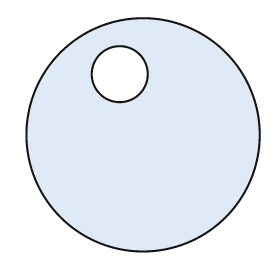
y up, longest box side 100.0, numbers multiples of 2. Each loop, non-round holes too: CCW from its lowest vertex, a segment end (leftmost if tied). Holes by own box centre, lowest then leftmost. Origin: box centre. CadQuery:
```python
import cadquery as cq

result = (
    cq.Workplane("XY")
    .moveTo(0.0, 0.0)
    .circle(50.0)
    .moveTo(-10.0, 26.0)
    .circle(12.0)
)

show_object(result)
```